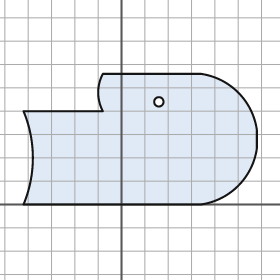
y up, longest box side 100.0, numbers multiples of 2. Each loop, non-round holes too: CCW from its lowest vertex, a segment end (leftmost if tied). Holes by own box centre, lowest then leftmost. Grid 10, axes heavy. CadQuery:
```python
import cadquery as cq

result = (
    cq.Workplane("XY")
    .moveTo(-42.0, 0.0)
    .lineTo(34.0, 0.0)
    .threePointArc((50.0, 8.0), (58.0, 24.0))
    .lineTo(58.0, 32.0)
    .threePointArc((50.0, 48.0), (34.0, 56.0))
    .lineTo(-8.0, 56.0)
    .threePointArc((-10.0, 48.0), (-8.0, 40.0))
    .lineTo(-42.0, 40.0)
    .threePointArc((-38.0, 20.0), (-42.0, 0.0))
    .close()
    .moveTo(16.0, 44.0)
    .circle(2.0)
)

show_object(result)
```